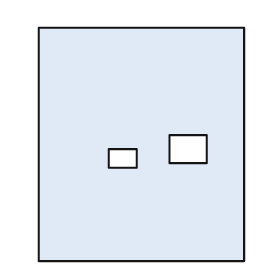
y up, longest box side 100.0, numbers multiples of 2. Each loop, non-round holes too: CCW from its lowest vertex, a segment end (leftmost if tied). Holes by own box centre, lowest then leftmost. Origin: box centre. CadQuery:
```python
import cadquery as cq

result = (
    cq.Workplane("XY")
    .moveTo(-44.0, -50.0)
    .lineTo(44.0, -50.0)
    .lineTo(44.0, 50.0)
    .lineTo(-44.0, 50.0)
    .close()
    .moveTo(-14.0, -10.0)
    .lineTo(-2.0, -10.0)
    .lineTo(-2.0, -2.0)
    .lineTo(-14.0, -2.0)
    .close()
    .moveTo(12.0, -8.0)
    .lineTo(28.0, -8.0)
    .lineTo(28.0, 4.0)
    .lineTo(12.0, 4.0)
    .close()
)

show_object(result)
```